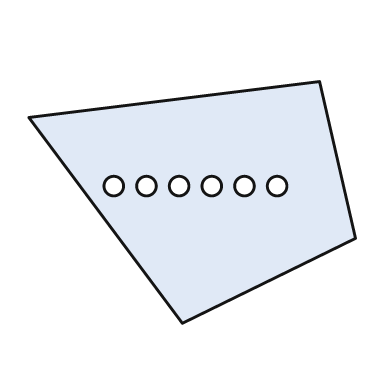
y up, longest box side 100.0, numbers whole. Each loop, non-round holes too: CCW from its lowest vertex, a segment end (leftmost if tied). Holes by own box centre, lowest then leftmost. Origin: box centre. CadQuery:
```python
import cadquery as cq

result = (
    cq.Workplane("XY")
    .moveTo(-3.0, -37.0)
    .lineTo(50.0, -11.0)
    .lineTo(39.0, 37.0)
    .lineTo(-50.0, 26.0)
    .close()
    .moveTo(-24.0, 5.0)
    .circle(3.0)
    .moveTo(-14.0, 5.0)
    .circle(3.0)
    .moveTo(-4.0, 5.0)
    .circle(3.0)
    .moveTo(6.0, 5.0)
    .circle(3.0)
    .moveTo(16.0, 5.0)
    .circle(3.0)
    .moveTo(26.0, 5.0)
    .circle(3.0)
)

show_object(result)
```